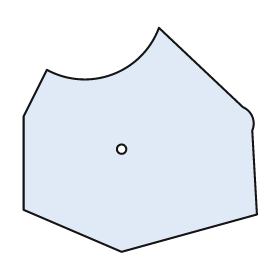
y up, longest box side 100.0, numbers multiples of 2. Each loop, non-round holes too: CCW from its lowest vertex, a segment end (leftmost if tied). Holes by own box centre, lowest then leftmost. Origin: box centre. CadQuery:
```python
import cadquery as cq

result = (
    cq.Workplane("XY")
    .moveTo(-8.0, -48.0)
    .lineTo(50.0, -32.0)
    .lineTo(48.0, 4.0)
    .threePointArc((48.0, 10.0), (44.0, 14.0))
    .lineTo(8.0, 48.0)
    .threePointArc((-12.0, 28.0), (-40.0, 30.0))
    .lineTo(-50.0, 10.0)
    .lineTo(-50.0, -30.0)
    .close()
    .moveTo(-8.0, -4.0)
    .circle(2.0)
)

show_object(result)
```